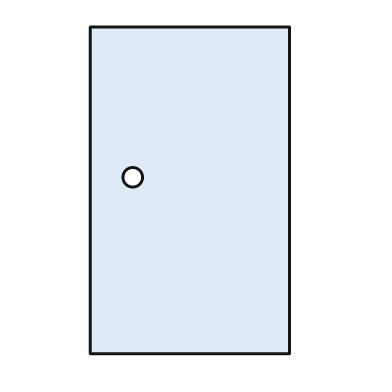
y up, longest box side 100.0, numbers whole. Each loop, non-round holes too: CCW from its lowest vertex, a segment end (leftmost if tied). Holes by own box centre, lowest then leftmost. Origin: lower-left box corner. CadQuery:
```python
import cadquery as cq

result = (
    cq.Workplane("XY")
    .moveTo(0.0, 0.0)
    .lineTo(61.0, 0.0)
    .lineTo(61.0, 100.0)
    .lineTo(0.0, 100.0)
    .close()
    .moveTo(13.0, 54.0)
    .circle(3.0)
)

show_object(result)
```